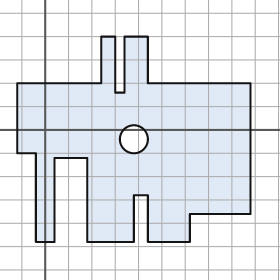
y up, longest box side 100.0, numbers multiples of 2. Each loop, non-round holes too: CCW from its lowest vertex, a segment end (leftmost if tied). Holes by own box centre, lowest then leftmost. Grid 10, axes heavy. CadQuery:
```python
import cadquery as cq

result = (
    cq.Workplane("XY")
    .moveTo(-4.0, -48.0)
    .lineTo(4.0, -48.0)
    .lineTo(4.0, -12.0)
    .lineTo(18.0, -12.0)
    .lineTo(18.0, -48.0)
    .lineTo(38.0, -48.0)
    .lineTo(38.0, -28.0)
    .lineTo(44.0, -28.0)
    .lineTo(44.0, -48.0)
    .lineTo(62.0, -48.0)
    .lineTo(62.0, -36.0)
    .lineTo(88.0, -36.0)
    .lineTo(88.0, 20.0)
    .lineTo(44.0, 20.0)
    .lineTo(44.0, 40.0)
    .lineTo(34.0, 40.0)
    .lineTo(34.0, 16.0)
    .lineTo(30.0, 16.0)
    .lineTo(30.0, 40.0)
    .lineTo(24.0, 40.0)
    .lineTo(24.0, 20.0)
    .lineTo(-12.0, 20.0)
    .lineTo(-12.0, -10.0)
    .lineTo(-4.0, -10.0)
    .close()
    .moveTo(38.0, -4.0)
    .circle(6.0)
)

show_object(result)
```